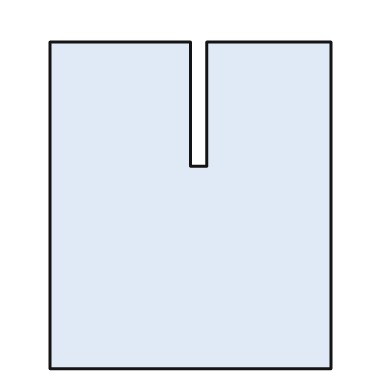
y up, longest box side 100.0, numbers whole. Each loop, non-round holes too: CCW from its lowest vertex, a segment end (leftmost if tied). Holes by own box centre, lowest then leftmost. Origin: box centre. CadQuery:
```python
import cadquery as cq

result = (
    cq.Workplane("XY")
    .moveTo(-43.0, -50.0)
    .lineTo(43.0, -50.0)
    .lineTo(43.0, 50.0)
    .lineTo(5.0, 50.0)
    .lineTo(5.0, 12.0)
    .lineTo(0.0, 12.0)
    .lineTo(0.0, 50.0)
    .lineTo(-43.0, 50.0)
    .close()
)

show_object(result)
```